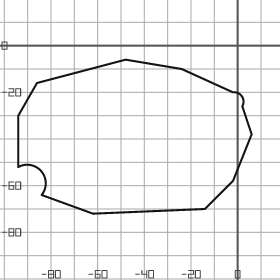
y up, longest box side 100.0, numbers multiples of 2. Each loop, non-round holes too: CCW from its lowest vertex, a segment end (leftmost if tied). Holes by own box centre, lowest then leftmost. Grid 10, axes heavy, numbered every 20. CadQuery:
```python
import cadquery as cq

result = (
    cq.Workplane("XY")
    .moveTo(-62.0, -72.0)
    .lineTo(-14.0, -70.0)
    .lineTo(-2.0, -58.0)
    .lineTo(6.0, -38.0)
    .lineTo(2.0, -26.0)
    .threePointArc((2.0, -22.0), (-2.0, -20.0))
    .lineTo(-24.0, -10.0)
    .lineTo(-48.0, -6.0)
    .lineTo(-86.0, -16.0)
    .lineTo(-94.0, -30.0)
    .lineTo(-94.0, -52.0)
    .threePointArc((-84.0, -54.0), (-84.0, -64.0))
    .close()
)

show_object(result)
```